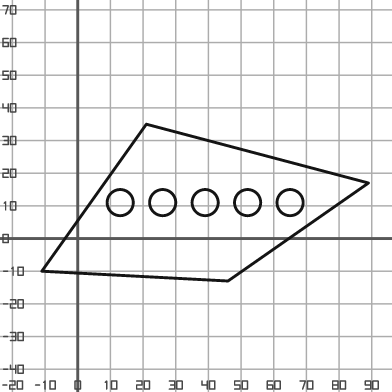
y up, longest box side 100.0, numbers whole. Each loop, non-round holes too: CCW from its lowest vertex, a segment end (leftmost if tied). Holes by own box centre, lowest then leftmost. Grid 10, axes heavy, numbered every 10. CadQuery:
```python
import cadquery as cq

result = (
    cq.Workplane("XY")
    .moveTo(46.0, -13.0)
    .lineTo(89.0, 17.0)
    .lineTo(21.0, 35.0)
    .lineTo(-11.0, -10.0)
    .close()
    .moveTo(13.0, 11.0)
    .circle(4.0)
    .moveTo(26.0, 11.0)
    .circle(4.0)
    .moveTo(39.0, 11.0)
    .circle(4.0)
    .moveTo(52.0, 11.0)
    .circle(4.0)
    .moveTo(65.0, 11.0)
    .circle(4.0)
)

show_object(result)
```